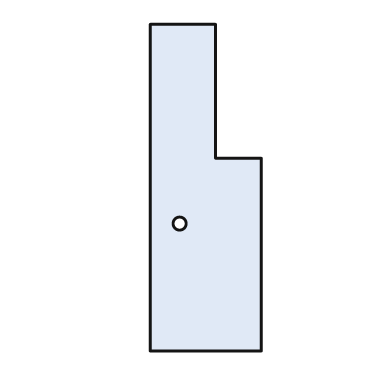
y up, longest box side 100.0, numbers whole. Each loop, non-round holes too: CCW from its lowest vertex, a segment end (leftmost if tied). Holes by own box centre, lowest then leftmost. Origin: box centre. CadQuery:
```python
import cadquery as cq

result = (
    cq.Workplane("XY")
    .moveTo(-17.0, -50.0)
    .lineTo(17.0, -50.0)
    .lineTo(17.0, 9.0)
    .lineTo(3.0, 9.0)
    .lineTo(3.0, 50.0)
    .lineTo(-17.0, 50.0)
    .close()
    .moveTo(-8.0, -11.0)
    .circle(2.0)
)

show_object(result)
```